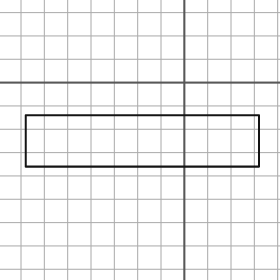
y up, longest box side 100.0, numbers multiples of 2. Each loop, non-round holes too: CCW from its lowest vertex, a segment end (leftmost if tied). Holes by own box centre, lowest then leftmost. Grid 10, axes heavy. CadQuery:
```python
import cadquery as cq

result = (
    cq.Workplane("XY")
    .moveTo(-68.0, -36.0)
    .lineTo(32.0, -36.0)
    .lineTo(32.0, -14.0)
    .lineTo(-68.0, -14.0)
    .close()
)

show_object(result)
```